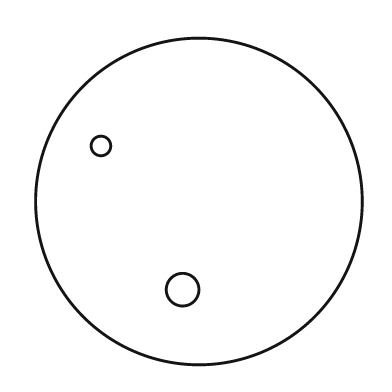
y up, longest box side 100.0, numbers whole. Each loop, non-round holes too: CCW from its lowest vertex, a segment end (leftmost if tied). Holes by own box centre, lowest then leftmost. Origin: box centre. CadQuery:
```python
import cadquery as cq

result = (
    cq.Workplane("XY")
    .moveTo(0.0, 0.0)
    .circle(50.0)
    .moveTo(-5.0, -27.0)
    .circle(5.0)
    .moveTo(-30.0, 17.0)
    .circle(3.0)
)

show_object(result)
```